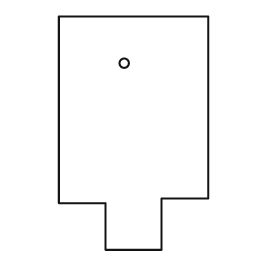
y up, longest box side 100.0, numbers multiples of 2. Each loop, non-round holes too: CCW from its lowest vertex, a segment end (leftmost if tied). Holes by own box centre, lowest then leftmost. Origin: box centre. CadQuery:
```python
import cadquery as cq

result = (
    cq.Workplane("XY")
    .moveTo(-12.0, -50.0)
    .lineTo(12.0, -50.0)
    .lineTo(12.0, -28.0)
    .lineTo(32.0, -28.0)
    .lineTo(32.0, 50.0)
    .lineTo(-32.0, 50.0)
    .lineTo(-32.0, -30.0)
    .lineTo(-12.0, -30.0)
    .close()
    .moveTo(-4.0, 30.0)
    .circle(2.0)
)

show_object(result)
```